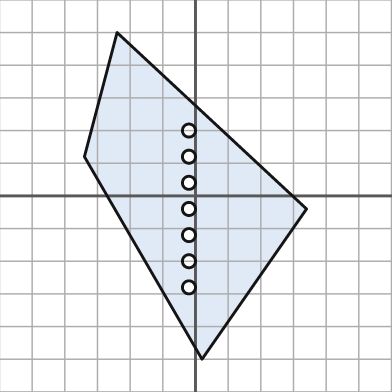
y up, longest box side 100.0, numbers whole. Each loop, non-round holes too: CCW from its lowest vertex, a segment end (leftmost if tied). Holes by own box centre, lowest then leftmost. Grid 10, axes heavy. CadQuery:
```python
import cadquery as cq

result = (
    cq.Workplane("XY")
    .moveTo(2.0, -50.0)
    .lineTo(34.0, -4.0)
    .lineTo(-24.0, 50.0)
    .lineTo(-34.0, 12.0)
    .close()
    .moveTo(-2.0, -28.0)
    .circle(2.0)
    .moveTo(-2.0, -20.0)
    .circle(2.0)
    .moveTo(-2.0, -12.0)
    .circle(2.0)
    .moveTo(-2.0, -4.0)
    .circle(2.0)
    .moveTo(-2.0, 4.0)
    .circle(2.0)
    .moveTo(-2.0, 12.0)
    .circle(2.0)
    .moveTo(-2.0, 20.0)
    .circle(2.0)
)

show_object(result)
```